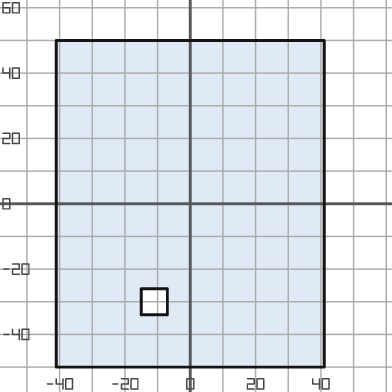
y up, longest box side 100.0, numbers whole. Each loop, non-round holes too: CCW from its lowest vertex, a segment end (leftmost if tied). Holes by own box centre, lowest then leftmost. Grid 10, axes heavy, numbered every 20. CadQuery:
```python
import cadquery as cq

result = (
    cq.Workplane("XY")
    .moveTo(-41.0, -50.0)
    .lineTo(41.0, -50.0)
    .lineTo(41.0, 50.0)
    .lineTo(-41.0, 50.0)
    .close()
    .moveTo(-15.0, -34.0)
    .lineTo(-7.0, -34.0)
    .lineTo(-7.0, -26.0)
    .lineTo(-15.0, -26.0)
    .close()
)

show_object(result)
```